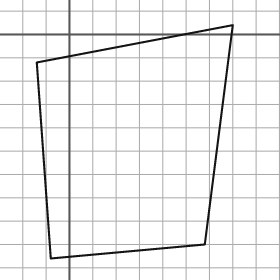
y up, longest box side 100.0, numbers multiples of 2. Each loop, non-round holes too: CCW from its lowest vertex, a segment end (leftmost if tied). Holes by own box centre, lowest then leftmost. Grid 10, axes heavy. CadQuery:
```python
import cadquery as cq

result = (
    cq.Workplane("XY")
    .moveTo(-8.0, -96.0)
    .lineTo(58.0, -90.0)
    .lineTo(70.0, 4.0)
    .lineTo(-14.0, -12.0)
    .close()
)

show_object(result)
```